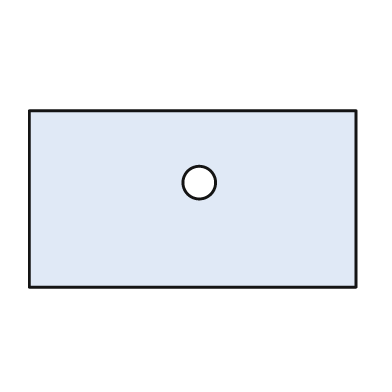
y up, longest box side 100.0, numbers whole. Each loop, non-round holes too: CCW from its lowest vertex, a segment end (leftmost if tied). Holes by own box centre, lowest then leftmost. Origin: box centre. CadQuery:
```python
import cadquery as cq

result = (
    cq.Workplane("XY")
    .moveTo(-50.0, -27.0)
    .lineTo(50.0, -27.0)
    .lineTo(50.0, 27.0)
    .lineTo(-50.0, 27.0)
    .close()
    .moveTo(2.0, 5.0)
    .circle(5.0)
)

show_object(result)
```